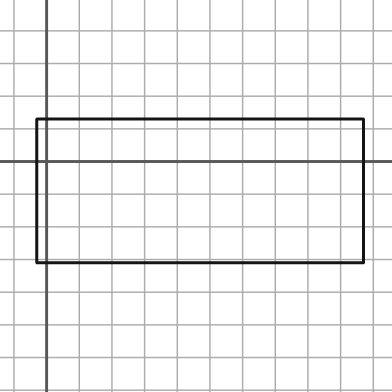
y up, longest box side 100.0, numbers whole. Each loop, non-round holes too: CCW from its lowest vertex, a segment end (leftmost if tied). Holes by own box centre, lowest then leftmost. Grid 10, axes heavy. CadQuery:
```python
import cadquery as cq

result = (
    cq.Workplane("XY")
    .moveTo(-3.0, -31.0)
    .lineTo(97.0, -31.0)
    .lineTo(97.0, 13.0)
    .lineTo(-3.0, 13.0)
    .close()
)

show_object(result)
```